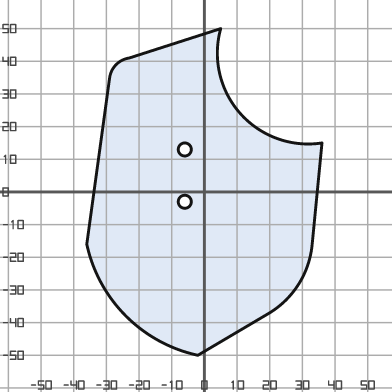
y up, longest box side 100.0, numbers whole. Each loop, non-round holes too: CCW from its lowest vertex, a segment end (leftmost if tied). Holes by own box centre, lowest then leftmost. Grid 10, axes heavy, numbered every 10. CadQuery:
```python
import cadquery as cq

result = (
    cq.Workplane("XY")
    .moveTo(-2.0, -50.0)
    .lineTo(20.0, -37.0)
    .threePointArc((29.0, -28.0), (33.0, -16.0))
    .lineTo(36.0, 15.0)
    .threePointArc((11.0, 24.0), (5.0, 50.0))
    .lineTo(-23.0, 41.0)
    .threePointArc((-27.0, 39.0), (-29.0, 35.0))
    .lineTo(-36.0, -16.0)
    .threePointArc((-24.0, -38.0), (-2.0, -50.0))
    .close()
    .moveTo(-6.0, -3.0)
    .circle(2.0)
    .moveTo(-6.0, 13.0)
    .circle(2.0)
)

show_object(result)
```